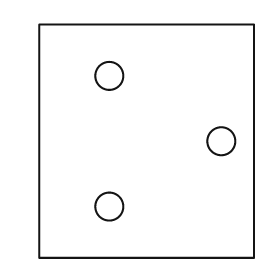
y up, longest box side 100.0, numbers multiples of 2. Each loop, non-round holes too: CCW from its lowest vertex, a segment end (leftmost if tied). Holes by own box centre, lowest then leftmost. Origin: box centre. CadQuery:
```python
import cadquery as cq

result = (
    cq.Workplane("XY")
    .moveTo(-46.0, -50.0)
    .lineTo(46.0, -50.0)
    .lineTo(46.0, 50.0)
    .lineTo(-46.0, 50.0)
    .close()
    .moveTo(-16.0, -28.0)
    .circle(6.0)
    .moveTo(32.0, 0.0)
    .circle(6.0)
    .moveTo(-16.0, 28.0)
    .circle(6.0)
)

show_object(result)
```